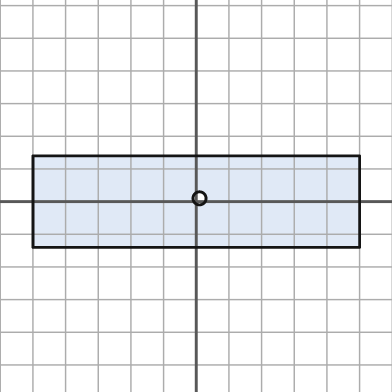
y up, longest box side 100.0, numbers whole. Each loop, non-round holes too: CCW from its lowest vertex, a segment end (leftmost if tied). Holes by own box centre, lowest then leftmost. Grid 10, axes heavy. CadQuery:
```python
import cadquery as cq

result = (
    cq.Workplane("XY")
    .moveTo(-50.0, -14.0)
    .lineTo(50.0, -14.0)
    .lineTo(50.0, 14.0)
    .lineTo(-50.0, 14.0)
    .close()
    .moveTo(1.0, 1.0)
    .circle(2.0)
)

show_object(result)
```